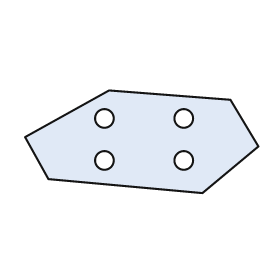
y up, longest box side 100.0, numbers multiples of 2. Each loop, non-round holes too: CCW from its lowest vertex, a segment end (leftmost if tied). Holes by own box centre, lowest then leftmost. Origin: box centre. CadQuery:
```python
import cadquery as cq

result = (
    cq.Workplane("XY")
    .moveTo(26.0, -22.0)
    .lineTo(50.0, -2.0)
    .lineTo(38.0, 18.0)
    .lineTo(-14.0, 22.0)
    .lineTo(-50.0, 2.0)
    .lineTo(-40.0, -16.0)
    .close()
    .moveTo(-16.0, -8.0)
    .circle(4.0)
    .moveTo(18.0, -8.0)
    .circle(4.0)
    .moveTo(-16.0, 10.0)
    .circle(4.0)
    .moveTo(18.0, 10.0)
    .circle(4.0)
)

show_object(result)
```